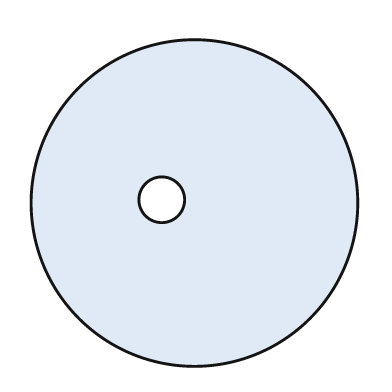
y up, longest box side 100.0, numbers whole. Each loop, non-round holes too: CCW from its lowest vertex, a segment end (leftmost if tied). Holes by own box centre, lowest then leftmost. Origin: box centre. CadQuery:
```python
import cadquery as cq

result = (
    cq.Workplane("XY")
    .moveTo(0.0, 0.0)
    .circle(50.0)
    .moveTo(-10.0, 1.0)
    .circle(7.0)
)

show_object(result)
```